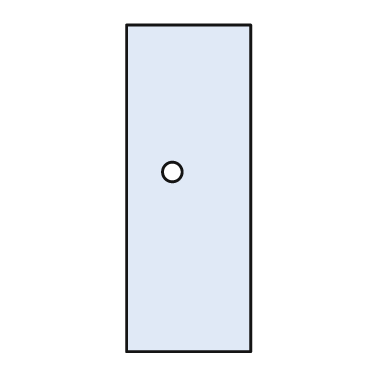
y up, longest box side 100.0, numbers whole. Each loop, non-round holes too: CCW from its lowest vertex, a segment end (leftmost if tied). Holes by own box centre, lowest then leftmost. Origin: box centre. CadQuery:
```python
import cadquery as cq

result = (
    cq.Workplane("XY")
    .moveTo(-19.0, -50.0)
    .lineTo(19.0, -50.0)
    .lineTo(19.0, 50.0)
    .lineTo(-19.0, 50.0)
    .close()
    .moveTo(-5.0, 5.0)
    .circle(3.0)
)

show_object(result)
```